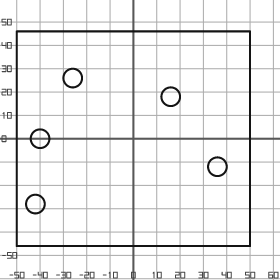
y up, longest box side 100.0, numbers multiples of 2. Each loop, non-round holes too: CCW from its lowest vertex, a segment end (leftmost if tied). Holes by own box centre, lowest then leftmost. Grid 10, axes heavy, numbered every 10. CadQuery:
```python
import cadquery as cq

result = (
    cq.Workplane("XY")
    .moveTo(-50.0, -46.0)
    .lineTo(50.0, -46.0)
    .lineTo(50.0, 46.0)
    .lineTo(-50.0, 46.0)
    .close()
    .moveTo(-42.0, -28.0)
    .circle(4.0)
    .moveTo(36.0, -12.0)
    .circle(4.0)
    .moveTo(-40.0, 0.0)
    .circle(4.0)
    .moveTo(16.0, 18.0)
    .circle(4.0)
    .moveTo(-26.0, 26.0)
    .circle(4.0)
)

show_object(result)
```